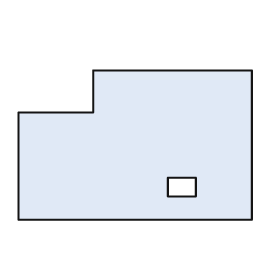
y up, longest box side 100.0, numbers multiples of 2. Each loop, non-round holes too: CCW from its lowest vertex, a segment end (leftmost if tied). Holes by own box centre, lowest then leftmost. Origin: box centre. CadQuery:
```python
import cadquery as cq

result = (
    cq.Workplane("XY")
    .moveTo(-50.0, -32.0)
    .lineTo(50.0, -32.0)
    .lineTo(50.0, 32.0)
    .lineTo(-18.0, 32.0)
    .lineTo(-18.0, 14.0)
    .lineTo(-50.0, 14.0)
    .close()
    .moveTo(14.0, -22.0)
    .lineTo(26.0, -22.0)
    .lineTo(26.0, -14.0)
    .lineTo(14.0, -14.0)
    .close()
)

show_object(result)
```